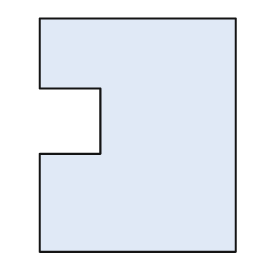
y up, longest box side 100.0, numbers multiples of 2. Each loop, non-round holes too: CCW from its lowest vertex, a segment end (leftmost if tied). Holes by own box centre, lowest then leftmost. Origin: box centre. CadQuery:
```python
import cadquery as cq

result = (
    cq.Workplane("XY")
    .moveTo(-42.0, -50.0)
    .lineTo(42.0, -50.0)
    .lineTo(42.0, 50.0)
    .lineTo(-42.0, 50.0)
    .lineTo(-42.0, 20.0)
    .lineTo(-16.0, 20.0)
    .lineTo(-16.0, -8.0)
    .lineTo(-42.0, -8.0)
    .close()
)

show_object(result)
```